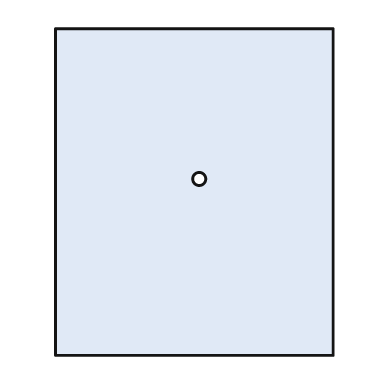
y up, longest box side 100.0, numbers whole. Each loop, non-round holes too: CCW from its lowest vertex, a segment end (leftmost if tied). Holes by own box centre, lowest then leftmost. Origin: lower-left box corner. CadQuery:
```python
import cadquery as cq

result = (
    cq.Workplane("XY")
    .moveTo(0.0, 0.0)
    .lineTo(85.0, 0.0)
    .lineTo(85.0, 100.0)
    .lineTo(0.0, 100.0)
    .close()
    .moveTo(44.0, 54.0)
    .circle(2.0)
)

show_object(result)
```